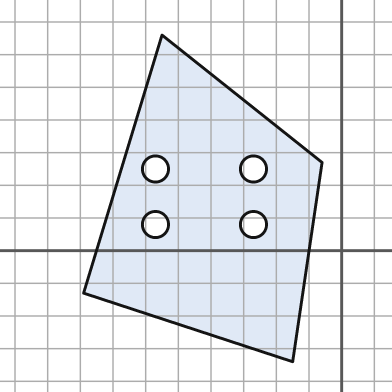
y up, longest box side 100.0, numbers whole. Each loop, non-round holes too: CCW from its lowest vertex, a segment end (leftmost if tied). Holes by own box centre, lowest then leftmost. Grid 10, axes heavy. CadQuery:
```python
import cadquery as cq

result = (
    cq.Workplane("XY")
    .moveTo(-15.0, -34.0)
    .lineTo(-6.0, 27.0)
    .lineTo(-55.0, 66.0)
    .lineTo(-79.0, -13.0)
    .close()
    .moveTo(-57.0, 8.0)
    .circle(4.0)
    .moveTo(-27.0, 8.0)
    .circle(4.0)
    .moveTo(-57.0, 25.0)
    .circle(4.0)
    .moveTo(-27.0, 25.0)
    .circle(4.0)
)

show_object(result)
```